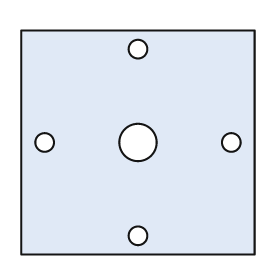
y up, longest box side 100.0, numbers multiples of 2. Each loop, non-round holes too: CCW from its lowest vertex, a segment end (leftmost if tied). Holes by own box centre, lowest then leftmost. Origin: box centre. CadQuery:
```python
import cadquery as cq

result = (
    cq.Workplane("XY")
    .moveTo(-50.0, -48.0)
    .lineTo(50.0, -48.0)
    .lineTo(50.0, 48.0)
    .lineTo(-50.0, 48.0)
    .close()
    .moveTo(0.0, -40.0)
    .circle(4.0)
    .moveTo(-40.0, 0.0)
    .circle(4.0)
    .moveTo(0.0, 0.0)
    .circle(8.0)
    .moveTo(40.0, 0.0)
    .circle(4.0)
    .moveTo(0.0, 40.0)
    .circle(4.0)
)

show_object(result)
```